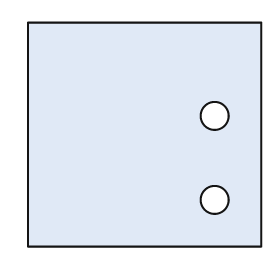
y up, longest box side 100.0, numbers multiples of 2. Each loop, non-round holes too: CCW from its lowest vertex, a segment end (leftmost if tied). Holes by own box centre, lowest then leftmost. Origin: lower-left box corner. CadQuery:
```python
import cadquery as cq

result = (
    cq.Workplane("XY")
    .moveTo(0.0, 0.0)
    .lineTo(100.0, 0.0)
    .lineTo(100.0, 96.0)
    .lineTo(0.0, 96.0)
    .close()
    .moveTo(80.0, 20.0)
    .circle(6.0)
    .moveTo(80.0, 56.0)
    .circle(6.0)
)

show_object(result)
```